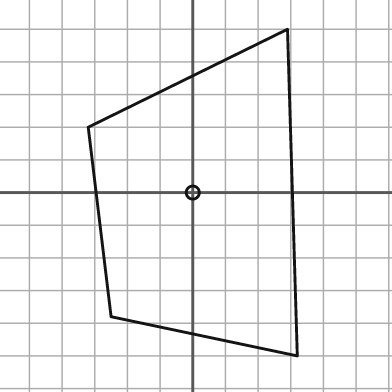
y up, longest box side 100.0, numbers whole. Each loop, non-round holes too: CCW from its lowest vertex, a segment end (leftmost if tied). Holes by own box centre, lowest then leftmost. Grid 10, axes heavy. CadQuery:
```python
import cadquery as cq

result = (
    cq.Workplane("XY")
    .moveTo(32.0, -50.0)
    .lineTo(29.0, 50.0)
    .lineTo(-32.0, 20.0)
    .lineTo(-25.0, -38.0)
    .close()
    .moveTo(0.0, 0.0)
    .circle(2.0)
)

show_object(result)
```